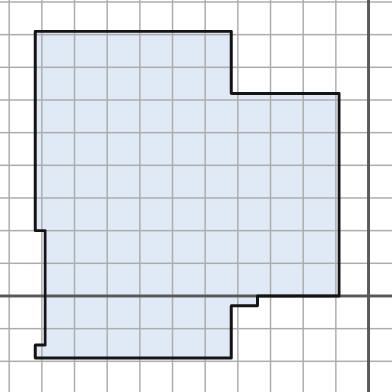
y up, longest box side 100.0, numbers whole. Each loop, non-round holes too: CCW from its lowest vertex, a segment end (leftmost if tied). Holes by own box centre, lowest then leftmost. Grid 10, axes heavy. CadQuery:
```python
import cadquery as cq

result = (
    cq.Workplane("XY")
    .moveTo(-102.0, -19.0)
    .lineTo(-42.0, -19.0)
    .lineTo(-42.0, -3.0)
    .lineTo(-34.0, -3.0)
    .lineTo(-34.0, 0.0)
    .lineTo(-9.0, 0.0)
    .lineTo(-9.0, 62.0)
    .lineTo(-42.0, 62.0)
    .lineTo(-42.0, 81.0)
    .lineTo(-102.0, 81.0)
    .lineTo(-102.0, 20.0)
    .lineTo(-99.0, 20.0)
    .lineTo(-99.0, -15.0)
    .lineTo(-102.0, -15.0)
    .close()
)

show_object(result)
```